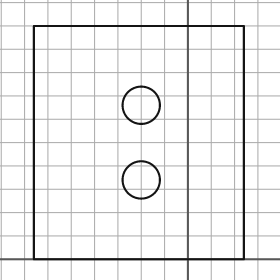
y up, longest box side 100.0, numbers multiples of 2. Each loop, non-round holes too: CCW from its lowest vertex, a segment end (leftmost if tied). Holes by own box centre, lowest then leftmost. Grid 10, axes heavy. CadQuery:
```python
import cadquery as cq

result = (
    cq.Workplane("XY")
    .moveTo(-66.0, 0.0)
    .lineTo(24.0, 0.0)
    .lineTo(24.0, 100.0)
    .lineTo(-66.0, 100.0)
    .close()
    .moveTo(-20.0, 34.0)
    .circle(8.0)
    .moveTo(-20.0, 66.0)
    .circle(8.0)
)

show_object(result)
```